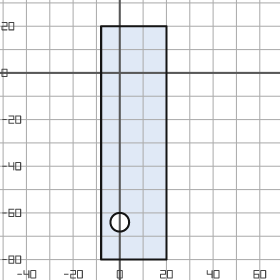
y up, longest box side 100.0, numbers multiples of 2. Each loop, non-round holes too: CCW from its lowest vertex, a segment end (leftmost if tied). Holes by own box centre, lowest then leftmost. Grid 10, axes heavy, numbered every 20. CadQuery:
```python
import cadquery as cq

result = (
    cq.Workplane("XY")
    .moveTo(-8.0, -80.0)
    .lineTo(20.0, -80.0)
    .lineTo(20.0, 20.0)
    .lineTo(-8.0, 20.0)
    .close()
    .moveTo(0.0, -64.0)
    .circle(4.0)
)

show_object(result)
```